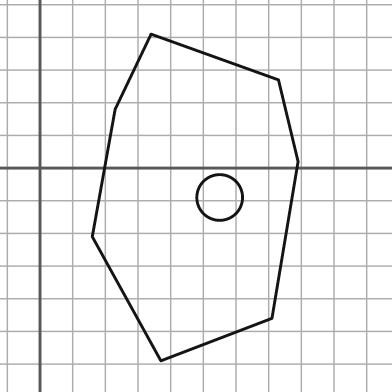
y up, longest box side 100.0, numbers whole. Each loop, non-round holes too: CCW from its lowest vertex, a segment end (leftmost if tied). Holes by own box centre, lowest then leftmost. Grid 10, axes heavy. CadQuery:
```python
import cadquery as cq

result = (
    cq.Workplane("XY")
    .moveTo(37.0, -59.0)
    .lineTo(71.0, -46.0)
    .lineTo(79.0, 2.0)
    .lineTo(73.0, 27.0)
    .lineTo(34.0, 41.0)
    .lineTo(23.0, 18.0)
    .lineTo(16.0, -21.0)
    .close()
    .moveTo(55.0, -9.0)
    .circle(7.0)
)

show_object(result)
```